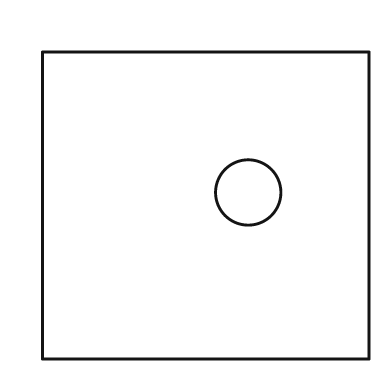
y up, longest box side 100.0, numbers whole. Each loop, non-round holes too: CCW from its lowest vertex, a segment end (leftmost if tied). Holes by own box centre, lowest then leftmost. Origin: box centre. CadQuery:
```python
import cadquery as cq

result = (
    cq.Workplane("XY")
    .moveTo(-50.0, -47.0)
    .lineTo(50.0, -47.0)
    .lineTo(50.0, 47.0)
    .lineTo(-50.0, 47.0)
    .close()
    .moveTo(13.0, 4.0)
    .circle(10.0)
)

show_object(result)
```